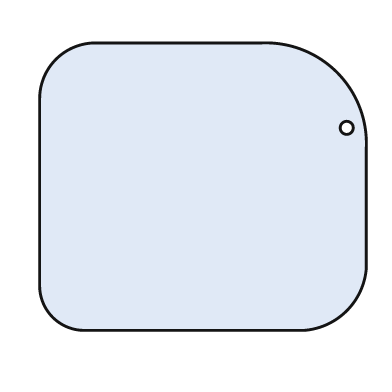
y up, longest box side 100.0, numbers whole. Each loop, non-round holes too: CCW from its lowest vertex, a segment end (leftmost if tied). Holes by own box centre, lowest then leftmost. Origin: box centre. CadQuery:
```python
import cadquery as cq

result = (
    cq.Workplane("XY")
    .moveTo(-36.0, -44.0)
    .lineTo(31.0, -44.0)
    .threePointArc((44.0, -38.0), (50.0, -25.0))
    .lineTo(50.0, 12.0)
    .threePointArc((41.0, 35.0), (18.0, 44.0))
    .lineTo(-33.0, 44.0)
    .threePointArc((-45.0, 39.0), (-50.0, 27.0))
    .lineTo(-50.0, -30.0)
    .threePointArc((-46.0, -40.0), (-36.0, -44.0))
    .close()
    .moveTo(44.0, 18.0)
    .circle(2.0)
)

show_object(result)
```